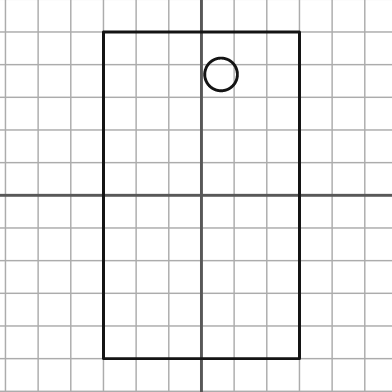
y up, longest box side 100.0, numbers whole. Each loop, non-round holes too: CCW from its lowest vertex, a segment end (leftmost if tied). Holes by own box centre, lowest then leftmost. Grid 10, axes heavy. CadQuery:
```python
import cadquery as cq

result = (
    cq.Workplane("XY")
    .moveTo(-30.0, -50.0)
    .lineTo(30.0, -50.0)
    .lineTo(30.0, 50.0)
    .lineTo(-30.0, 50.0)
    .close()
    .moveTo(6.0, 37.0)
    .circle(5.0)
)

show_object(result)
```